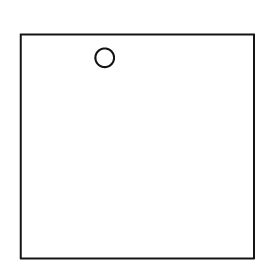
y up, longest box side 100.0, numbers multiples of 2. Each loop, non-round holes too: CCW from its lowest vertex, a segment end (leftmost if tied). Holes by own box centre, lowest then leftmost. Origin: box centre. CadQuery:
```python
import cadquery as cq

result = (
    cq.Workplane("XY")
    .moveTo(-50.0, -48.0)
    .lineTo(50.0, -48.0)
    .lineTo(50.0, 48.0)
    .lineTo(-50.0, 48.0)
    .close()
    .moveTo(-14.0, 38.0)
    .circle(4.0)
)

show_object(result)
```